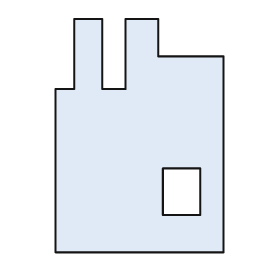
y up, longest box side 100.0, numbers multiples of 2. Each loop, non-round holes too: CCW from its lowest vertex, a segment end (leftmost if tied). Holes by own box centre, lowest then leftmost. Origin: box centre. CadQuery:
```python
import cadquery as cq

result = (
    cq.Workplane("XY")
    .moveTo(-36.0, -50.0)
    .lineTo(36.0, -50.0)
    .lineTo(36.0, 34.0)
    .lineTo(8.0, 34.0)
    .lineTo(8.0, 50.0)
    .lineTo(-6.0, 50.0)
    .lineTo(-6.0, 20.0)
    .lineTo(-16.0, 20.0)
    .lineTo(-16.0, 50.0)
    .lineTo(-28.0, 50.0)
    .lineTo(-28.0, 20.0)
    .lineTo(-36.0, 20.0)
    .close()
    .moveTo(10.0, -34.0)
    .lineTo(26.0, -34.0)
    .lineTo(26.0, -14.0)
    .lineTo(10.0, -14.0)
    .close()
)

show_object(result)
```